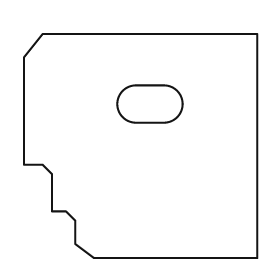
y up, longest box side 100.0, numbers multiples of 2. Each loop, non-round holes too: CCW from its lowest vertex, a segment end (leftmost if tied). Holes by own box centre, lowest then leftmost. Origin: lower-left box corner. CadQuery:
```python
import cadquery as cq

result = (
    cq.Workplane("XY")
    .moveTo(30.0, 0.0)
    .lineTo(100.0, 0.0)
    .lineTo(100.0, 96.0)
    .lineTo(8.0, 96.0)
    .lineTo(0.0, 86.0)
    .lineTo(0.0, 40.0)
    .lineTo(8.0, 40.0)
    .lineTo(12.0, 36.0)
    .lineTo(12.0, 20.0)
    .lineTo(18.0, 20.0)
    .lineTo(22.0, 16.0)
    .lineTo(22.0, 6.0)
    .close()
    .moveTo(48.0, 58.0)
    .lineTo(60.0, 58.0)
    .threePointArc((68.0, 66.0), (60.0, 74.0))
    .lineTo(48.0, 74.0)
    .threePointArc((40.0, 66.0), (48.0, 58.0))
    .close()
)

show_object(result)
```